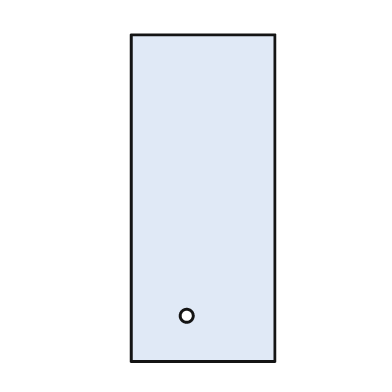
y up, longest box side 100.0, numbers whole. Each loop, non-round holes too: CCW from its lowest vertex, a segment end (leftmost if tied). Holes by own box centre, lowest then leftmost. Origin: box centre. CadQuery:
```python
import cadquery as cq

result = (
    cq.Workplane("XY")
    .moveTo(-22.0, -50.0)
    .lineTo(22.0, -50.0)
    .lineTo(22.0, 50.0)
    .lineTo(-22.0, 50.0)
    .close()
    .moveTo(-5.0, -36.0)
    .circle(2.0)
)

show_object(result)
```